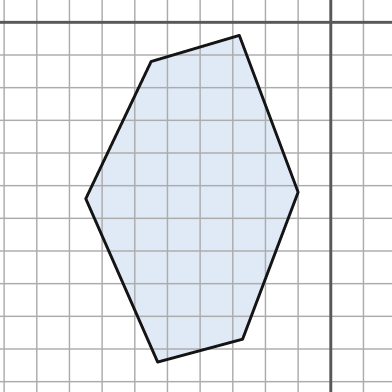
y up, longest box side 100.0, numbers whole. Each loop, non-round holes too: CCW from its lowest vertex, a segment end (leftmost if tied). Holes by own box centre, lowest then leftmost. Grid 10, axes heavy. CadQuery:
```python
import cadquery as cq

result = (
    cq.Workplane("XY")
    .moveTo(-53.0, -104.0)
    .lineTo(-27.0, -97.0)
    .lineTo(-10.0, -52.0)
    .lineTo(-28.0, -4.0)
    .lineTo(-55.0, -12.0)
    .lineTo(-75.0, -54.0)
    .close()
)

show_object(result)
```